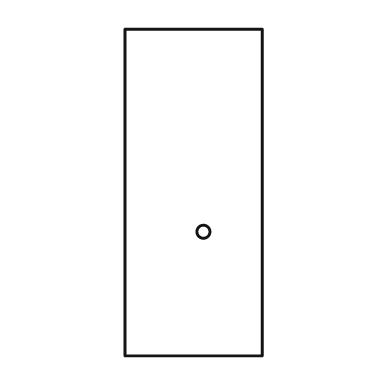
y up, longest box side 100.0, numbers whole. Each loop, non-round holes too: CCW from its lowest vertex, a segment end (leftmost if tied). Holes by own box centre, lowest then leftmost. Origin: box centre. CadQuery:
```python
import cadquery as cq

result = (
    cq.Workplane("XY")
    .moveTo(-21.0, -50.0)
    .lineTo(21.0, -50.0)
    .lineTo(21.0, 50.0)
    .lineTo(-21.0, 50.0)
    .close()
    .moveTo(3.0, -12.0)
    .circle(2.0)
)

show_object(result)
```